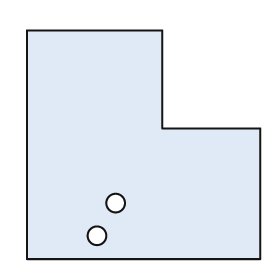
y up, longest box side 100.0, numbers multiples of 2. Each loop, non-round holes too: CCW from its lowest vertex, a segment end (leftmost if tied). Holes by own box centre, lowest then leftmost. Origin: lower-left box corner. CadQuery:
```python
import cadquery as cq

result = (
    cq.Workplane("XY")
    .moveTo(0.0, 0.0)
    .lineTo(100.0, 0.0)
    .lineTo(100.0, 56.0)
    .lineTo(58.0, 56.0)
    .lineTo(58.0, 98.0)
    .lineTo(0.0, 98.0)
    .close()
    .moveTo(30.0, 10.0)
    .circle(4.0)
    .moveTo(38.0, 24.0)
    .circle(4.0)
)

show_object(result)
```